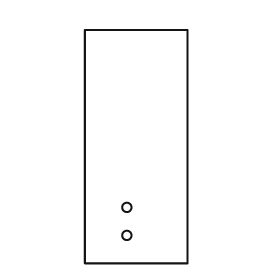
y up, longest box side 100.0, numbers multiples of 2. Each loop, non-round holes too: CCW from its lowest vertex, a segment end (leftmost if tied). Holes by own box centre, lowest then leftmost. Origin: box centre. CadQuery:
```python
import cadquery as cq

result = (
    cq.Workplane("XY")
    .moveTo(-22.0, -50.0)
    .lineTo(22.0, -50.0)
    .lineTo(22.0, 50.0)
    .lineTo(-22.0, 50.0)
    .close()
    .moveTo(-4.0, -38.0)
    .circle(2.0)
    .moveTo(-4.0, -26.0)
    .circle(2.0)
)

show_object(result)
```